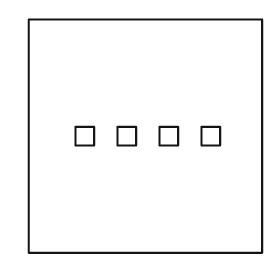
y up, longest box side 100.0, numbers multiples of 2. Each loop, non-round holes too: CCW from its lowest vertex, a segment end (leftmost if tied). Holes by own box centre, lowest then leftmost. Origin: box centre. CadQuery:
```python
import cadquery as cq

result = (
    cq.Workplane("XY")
    .moveTo(-50.0, -50.0)
    .lineTo(50.0, -50.0)
    .lineTo(50.0, 50.0)
    .lineTo(-50.0, 50.0)
    .close()
    .moveTo(-30.0, -4.0)
    .lineTo(-22.0, -4.0)
    .lineTo(-22.0, 4.0)
    .lineTo(-30.0, 4.0)
    .close()
    .moveTo(-12.0, -4.0)
    .lineTo(-4.0, -4.0)
    .lineTo(-4.0, 4.0)
    .lineTo(-12.0, 4.0)
    .close()
    .moveTo(6.0, -4.0)
    .lineTo(14.0, -4.0)
    .lineTo(14.0, 4.0)
    .lineTo(6.0, 4.0)
    .close()
    .moveTo(24.0, -4.0)
    .lineTo(32.0, -4.0)
    .lineTo(32.0, 4.0)
    .lineTo(24.0, 4.0)
    .close()
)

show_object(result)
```